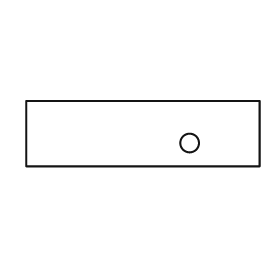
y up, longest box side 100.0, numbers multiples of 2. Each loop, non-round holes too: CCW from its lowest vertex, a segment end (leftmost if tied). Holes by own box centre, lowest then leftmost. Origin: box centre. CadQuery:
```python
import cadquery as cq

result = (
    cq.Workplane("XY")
    .moveTo(-50.0, -14.0)
    .lineTo(50.0, -14.0)
    .lineTo(50.0, 14.0)
    .lineTo(-50.0, 14.0)
    .close()
    .moveTo(20.0, -4.0)
    .circle(4.0)
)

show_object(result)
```